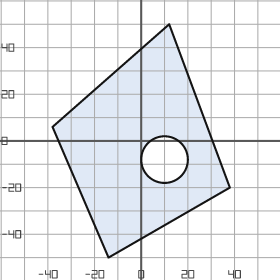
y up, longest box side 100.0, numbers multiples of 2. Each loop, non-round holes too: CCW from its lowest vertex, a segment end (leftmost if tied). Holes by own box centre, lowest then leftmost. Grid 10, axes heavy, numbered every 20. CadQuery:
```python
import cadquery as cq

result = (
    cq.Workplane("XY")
    .moveTo(-14.0, -50.0)
    .lineTo(38.0, -20.0)
    .lineTo(12.0, 50.0)
    .lineTo(-38.0, 6.0)
    .close()
    .moveTo(10.0, -8.0)
    .circle(10.0)
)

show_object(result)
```